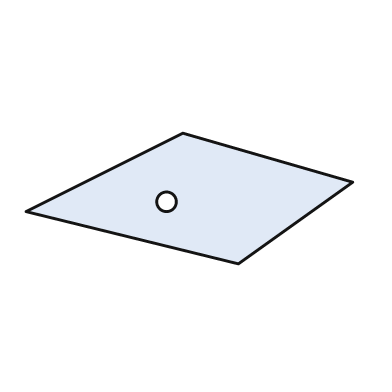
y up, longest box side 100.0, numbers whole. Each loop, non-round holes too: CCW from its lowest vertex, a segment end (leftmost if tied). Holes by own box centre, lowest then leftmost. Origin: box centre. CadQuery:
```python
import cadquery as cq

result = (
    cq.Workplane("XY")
    .moveTo(15.0, -20.0)
    .lineTo(50.0, 5.0)
    .lineTo(-2.0, 20.0)
    .lineTo(-50.0, -4.0)
    .close()
    .moveTo(-7.0, -1.0)
    .circle(3.0)
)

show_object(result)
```